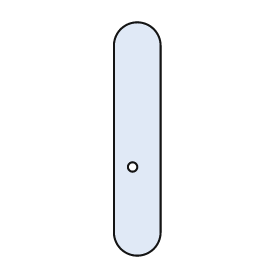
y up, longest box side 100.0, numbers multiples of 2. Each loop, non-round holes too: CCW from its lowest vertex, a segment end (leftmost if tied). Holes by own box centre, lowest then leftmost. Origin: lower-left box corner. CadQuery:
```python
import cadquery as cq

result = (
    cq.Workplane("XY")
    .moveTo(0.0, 10.0)
    .threePointArc((10.0, 0.0), (20.0, 10.0))
    .lineTo(20.0, 90.0)
    .threePointArc((10.0, 100.0), (0.0, 90.0))
    .close()
    .moveTo(8.0, 38.0)
    .circle(2.0)
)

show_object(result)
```